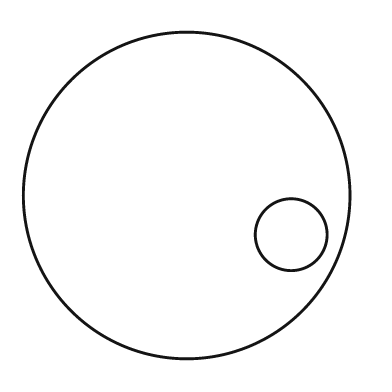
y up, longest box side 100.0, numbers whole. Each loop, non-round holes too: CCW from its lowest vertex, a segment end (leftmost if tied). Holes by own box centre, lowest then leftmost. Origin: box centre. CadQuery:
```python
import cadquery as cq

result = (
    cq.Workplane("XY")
    .moveTo(0.0, 0.0)
    .circle(50.0)
    .moveTo(32.0, -12.0)
    .circle(11.0)
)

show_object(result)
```